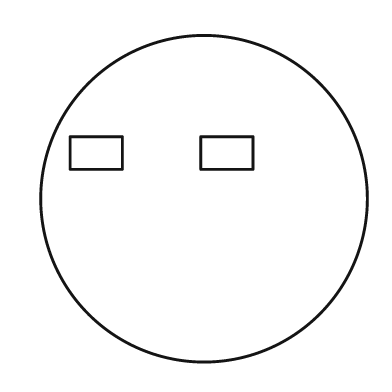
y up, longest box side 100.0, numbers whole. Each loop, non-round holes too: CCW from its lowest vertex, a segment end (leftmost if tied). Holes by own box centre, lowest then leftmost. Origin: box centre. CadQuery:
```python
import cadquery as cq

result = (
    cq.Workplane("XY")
    .moveTo(0.0, 0.0)
    .circle(50.0)
    .moveTo(-41.0, 9.0)
    .lineTo(-25.0, 9.0)
    .lineTo(-25.0, 19.0)
    .lineTo(-41.0, 19.0)
    .close()
    .moveTo(-1.0, 9.0)
    .lineTo(15.0, 9.0)
    .lineTo(15.0, 19.0)
    .lineTo(-1.0, 19.0)
    .close()
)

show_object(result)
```